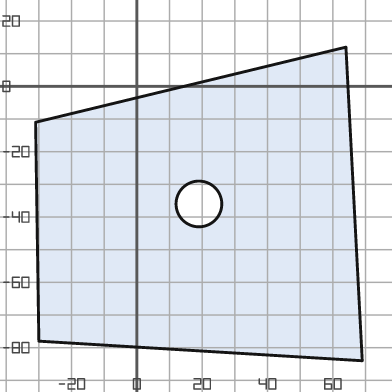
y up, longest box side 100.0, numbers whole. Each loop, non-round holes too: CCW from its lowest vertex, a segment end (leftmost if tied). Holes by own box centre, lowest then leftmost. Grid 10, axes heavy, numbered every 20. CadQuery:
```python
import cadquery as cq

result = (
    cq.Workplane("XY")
    .moveTo(69.0, -84.0)
    .lineTo(64.0, 12.0)
    .lineTo(-31.0, -11.0)
    .lineTo(-30.0, -78.0)
    .close()
    .moveTo(19.0, -36.0)
    .circle(7.0)
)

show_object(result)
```